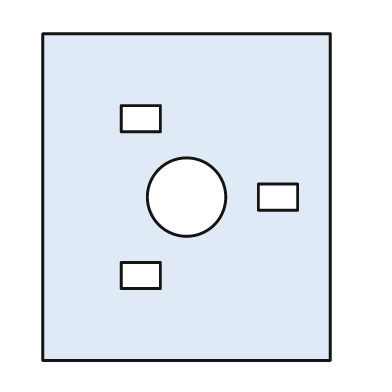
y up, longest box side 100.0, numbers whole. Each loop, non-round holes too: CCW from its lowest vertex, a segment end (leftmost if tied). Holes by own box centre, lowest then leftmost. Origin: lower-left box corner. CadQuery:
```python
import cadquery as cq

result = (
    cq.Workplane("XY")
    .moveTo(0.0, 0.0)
    .lineTo(88.0, 0.0)
    .lineTo(88.0, 100.0)
    .lineTo(0.0, 100.0)
    .close()
    .moveTo(24.0, 22.0)
    .lineTo(36.0, 22.0)
    .lineTo(36.0, 30.0)
    .lineTo(24.0, 30.0)
    .close()
    .moveTo(44.0, 50.0)
    .circle(12.0)
    .moveTo(66.0, 46.0)
    .lineTo(78.0, 46.0)
    .lineTo(78.0, 54.0)
    .lineTo(66.0, 54.0)
    .close()
    .moveTo(24.0, 70.0)
    .lineTo(36.0, 70.0)
    .lineTo(36.0, 78.0)
    .lineTo(24.0, 78.0)
    .close()
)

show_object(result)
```